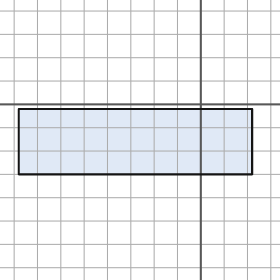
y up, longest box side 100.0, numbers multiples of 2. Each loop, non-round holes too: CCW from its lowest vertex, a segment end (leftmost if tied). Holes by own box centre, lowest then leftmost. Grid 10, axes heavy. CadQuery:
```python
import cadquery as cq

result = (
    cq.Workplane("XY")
    .moveTo(-78.0, -30.0)
    .lineTo(22.0, -30.0)
    .lineTo(22.0, -2.0)
    .lineTo(-78.0, -2.0)
    .close()
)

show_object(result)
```